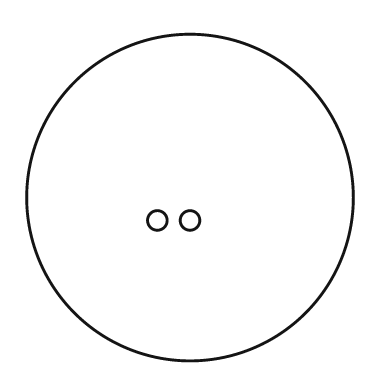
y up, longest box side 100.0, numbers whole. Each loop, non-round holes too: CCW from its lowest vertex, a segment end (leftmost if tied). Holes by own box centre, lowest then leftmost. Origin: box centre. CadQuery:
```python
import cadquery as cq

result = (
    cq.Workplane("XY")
    .moveTo(0.0, 0.0)
    .circle(50.0)
    .moveTo(-10.0, -7.0)
    .circle(3.0)
    .moveTo(0.0, -7.0)
    .circle(3.0)
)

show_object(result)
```